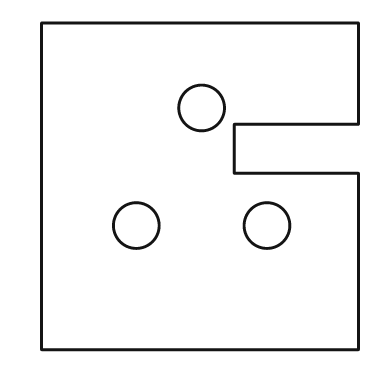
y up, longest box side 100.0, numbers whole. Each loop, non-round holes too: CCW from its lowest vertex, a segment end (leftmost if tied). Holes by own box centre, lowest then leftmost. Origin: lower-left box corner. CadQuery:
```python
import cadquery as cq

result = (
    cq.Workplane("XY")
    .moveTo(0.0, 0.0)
    .lineTo(97.0, 0.0)
    .lineTo(97.0, 54.0)
    .lineTo(59.0, 54.0)
    .lineTo(59.0, 69.0)
    .lineTo(97.0, 69.0)
    .lineTo(97.0, 100.0)
    .lineTo(0.0, 100.0)
    .close()
    .moveTo(29.0, 38.0)
    .circle(7.0)
    .moveTo(69.0, 38.0)
    .circle(7.0)
    .moveTo(49.0, 74.0)
    .circle(7.0)
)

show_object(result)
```